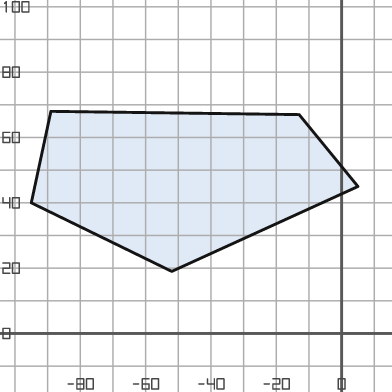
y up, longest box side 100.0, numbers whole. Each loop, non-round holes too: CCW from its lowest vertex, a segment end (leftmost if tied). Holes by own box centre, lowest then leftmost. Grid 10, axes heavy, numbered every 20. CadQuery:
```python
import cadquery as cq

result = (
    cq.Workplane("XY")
    .moveTo(-52.0, 19.0)
    .lineTo(5.0, 45.0)
    .lineTo(-13.0, 67.0)
    .lineTo(-89.0, 68.0)
    .lineTo(-95.0, 40.0)
    .close()
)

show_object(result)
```